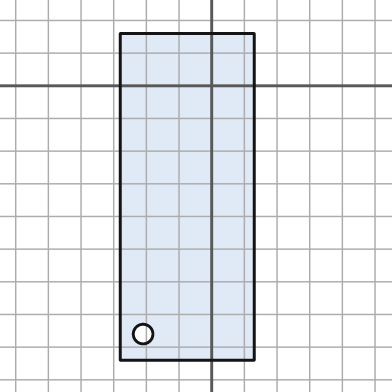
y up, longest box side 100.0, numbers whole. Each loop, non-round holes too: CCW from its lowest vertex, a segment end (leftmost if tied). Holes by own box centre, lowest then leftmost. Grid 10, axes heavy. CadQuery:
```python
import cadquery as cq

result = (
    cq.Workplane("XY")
    .moveTo(-28.0, -84.0)
    .lineTo(13.0, -84.0)
    .lineTo(13.0, 16.0)
    .lineTo(-28.0, 16.0)
    .close()
    .moveTo(-21.0, -76.0)
    .circle(3.0)
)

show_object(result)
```